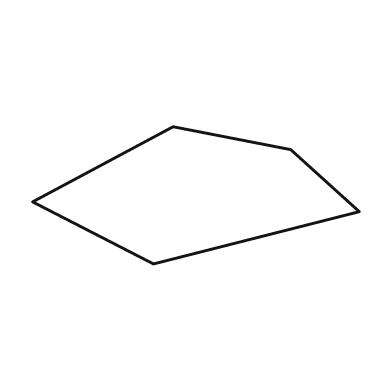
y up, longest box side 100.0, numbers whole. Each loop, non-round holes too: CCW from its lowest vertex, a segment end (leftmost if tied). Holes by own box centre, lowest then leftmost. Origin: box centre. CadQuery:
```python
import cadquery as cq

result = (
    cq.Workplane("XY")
    .moveTo(-13.0, -21.0)
    .lineTo(50.0, -5.0)
    .lineTo(29.0, 14.0)
    .lineTo(-7.0, 21.0)
    .lineTo(-50.0, -2.0)
    .close()
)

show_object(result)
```